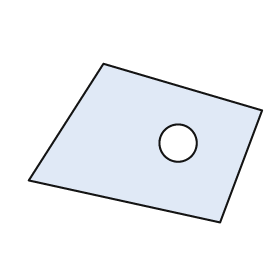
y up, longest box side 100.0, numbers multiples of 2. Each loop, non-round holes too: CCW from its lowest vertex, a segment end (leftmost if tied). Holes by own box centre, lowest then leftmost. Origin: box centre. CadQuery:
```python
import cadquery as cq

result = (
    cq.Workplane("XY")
    .moveTo(32.0, -34.0)
    .lineTo(50.0, 14.0)
    .lineTo(-18.0, 34.0)
    .lineTo(-50.0, -16.0)
    .close()
    .moveTo(14.0, 0.0)
    .circle(8.0)
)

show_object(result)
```